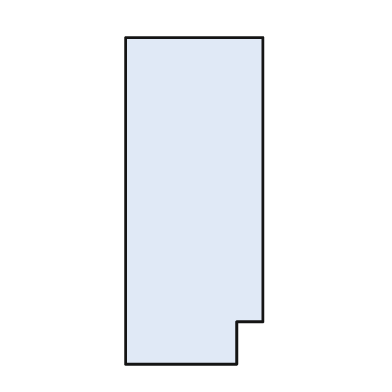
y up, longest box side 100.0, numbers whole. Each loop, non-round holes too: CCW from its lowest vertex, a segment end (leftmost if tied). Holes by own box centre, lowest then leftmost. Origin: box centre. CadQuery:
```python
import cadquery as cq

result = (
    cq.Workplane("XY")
    .moveTo(-21.0, -50.0)
    .lineTo(13.0, -50.0)
    .lineTo(13.0, -37.0)
    .lineTo(21.0, -37.0)
    .lineTo(21.0, 50.0)
    .lineTo(-21.0, 50.0)
    .close()
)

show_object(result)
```